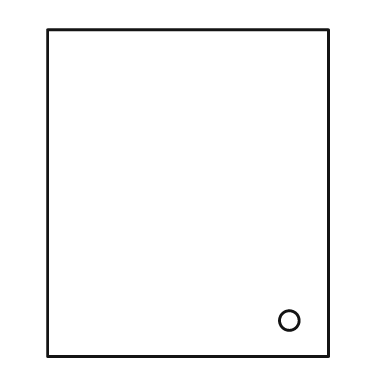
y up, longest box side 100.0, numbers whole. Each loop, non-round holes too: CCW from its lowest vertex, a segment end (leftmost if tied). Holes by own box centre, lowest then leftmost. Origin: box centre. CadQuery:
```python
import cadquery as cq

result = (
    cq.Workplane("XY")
    .moveTo(-43.0, -50.0)
    .lineTo(43.0, -50.0)
    .lineTo(43.0, 50.0)
    .lineTo(-43.0, 50.0)
    .close()
    .moveTo(31.0, -39.0)
    .circle(3.0)
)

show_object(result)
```